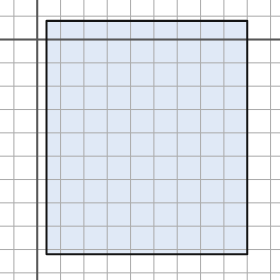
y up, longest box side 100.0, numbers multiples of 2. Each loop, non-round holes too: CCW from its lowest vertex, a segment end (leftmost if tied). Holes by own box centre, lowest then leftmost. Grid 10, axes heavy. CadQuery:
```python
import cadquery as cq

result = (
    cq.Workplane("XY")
    .moveTo(4.0, -92.0)
    .lineTo(90.0, -92.0)
    .lineTo(90.0, 8.0)
    .lineTo(4.0, 8.0)
    .close()
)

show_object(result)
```